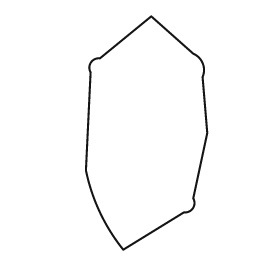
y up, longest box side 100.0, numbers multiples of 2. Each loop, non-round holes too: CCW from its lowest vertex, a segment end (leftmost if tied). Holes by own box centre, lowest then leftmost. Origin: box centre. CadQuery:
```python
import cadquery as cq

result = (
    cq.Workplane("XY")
    .moveTo(-10.0, -50.0)
    .lineTo(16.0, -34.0)
    .threePointArc((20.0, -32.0), (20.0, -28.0))
    .lineTo(26.0, 0.0)
    .lineTo(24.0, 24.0)
    .threePointArc((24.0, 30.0), (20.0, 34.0))
    .lineTo(2.0, 50.0)
    .lineTo(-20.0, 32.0)
    .threePointArc((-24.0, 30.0), (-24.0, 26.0))
    .lineTo(-26.0, -16.0)
    .threePointArc((-20.0, -34.0), (-10.0, -50.0))
    .close()
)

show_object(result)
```